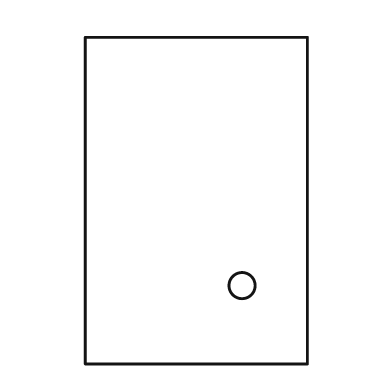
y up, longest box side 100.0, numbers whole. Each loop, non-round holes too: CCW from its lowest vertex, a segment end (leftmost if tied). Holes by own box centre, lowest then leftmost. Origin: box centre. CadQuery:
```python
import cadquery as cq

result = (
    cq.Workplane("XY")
    .moveTo(-34.0, -50.0)
    .lineTo(34.0, -50.0)
    .lineTo(34.0, 50.0)
    .lineTo(-34.0, 50.0)
    .close()
    .moveTo(14.0, -26.0)
    .circle(4.0)
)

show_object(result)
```